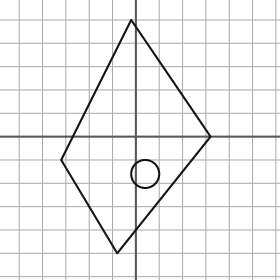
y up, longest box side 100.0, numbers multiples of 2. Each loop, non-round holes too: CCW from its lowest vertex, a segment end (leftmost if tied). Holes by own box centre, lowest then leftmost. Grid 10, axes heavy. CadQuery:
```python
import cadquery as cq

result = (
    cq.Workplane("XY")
    .moveTo(-8.0, -50.0)
    .lineTo(32.0, 0.0)
    .lineTo(-2.0, 50.0)
    .lineTo(-32.0, -10.0)
    .close()
    .moveTo(4.0, -16.0)
    .circle(6.0)
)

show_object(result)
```